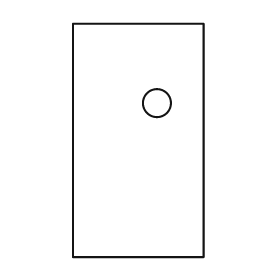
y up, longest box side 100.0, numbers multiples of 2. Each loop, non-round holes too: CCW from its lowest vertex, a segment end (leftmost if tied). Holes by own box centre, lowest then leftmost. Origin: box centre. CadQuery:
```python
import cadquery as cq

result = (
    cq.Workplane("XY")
    .moveTo(-28.0, -50.0)
    .lineTo(28.0, -50.0)
    .lineTo(28.0, 50.0)
    .lineTo(-28.0, 50.0)
    .close()
    .moveTo(8.0, 16.0)
    .circle(6.0)
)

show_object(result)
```